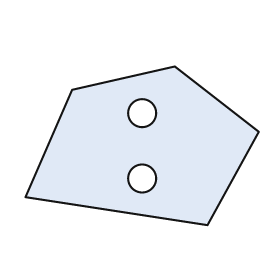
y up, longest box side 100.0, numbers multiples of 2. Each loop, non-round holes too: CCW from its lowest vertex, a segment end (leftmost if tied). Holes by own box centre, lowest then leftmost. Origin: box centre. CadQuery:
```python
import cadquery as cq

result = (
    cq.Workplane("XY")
    .moveTo(28.0, -34.0)
    .lineTo(50.0, 6.0)
    .lineTo(14.0, 34.0)
    .lineTo(-30.0, 24.0)
    .lineTo(-50.0, -22.0)
    .close()
    .moveTo(0.0, -14.0)
    .circle(6.0)
    .moveTo(0.0, 14.0)
    .circle(6.0)
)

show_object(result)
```